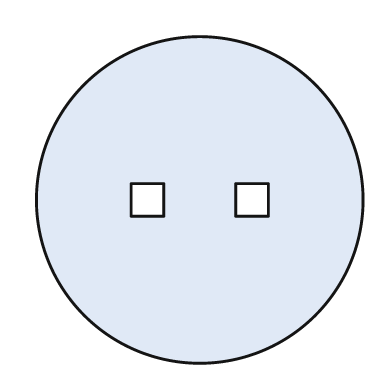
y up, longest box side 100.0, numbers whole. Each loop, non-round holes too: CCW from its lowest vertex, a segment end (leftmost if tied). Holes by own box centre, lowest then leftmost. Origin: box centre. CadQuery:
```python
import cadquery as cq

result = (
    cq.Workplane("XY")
    .moveTo(0.0, 0.0)
    .circle(50.0)
    .moveTo(-21.0, -5.0)
    .lineTo(-11.0, -5.0)
    .lineTo(-11.0, 5.0)
    .lineTo(-21.0, 5.0)
    .close()
    .moveTo(11.0, -5.0)
    .lineTo(21.0, -5.0)
    .lineTo(21.0, 5.0)
    .lineTo(11.0, 5.0)
    .close()
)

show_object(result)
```